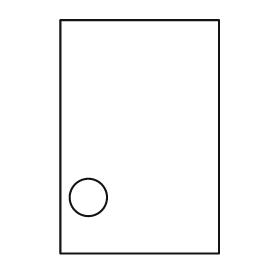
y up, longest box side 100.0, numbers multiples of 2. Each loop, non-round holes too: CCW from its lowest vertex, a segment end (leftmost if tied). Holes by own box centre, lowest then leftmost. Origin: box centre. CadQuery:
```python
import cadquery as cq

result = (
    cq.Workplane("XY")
    .moveTo(-34.0, -50.0)
    .lineTo(34.0, -50.0)
    .lineTo(34.0, 50.0)
    .lineTo(-34.0, 50.0)
    .close()
    .moveTo(-22.0, -26.0)
    .circle(8.0)
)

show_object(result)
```